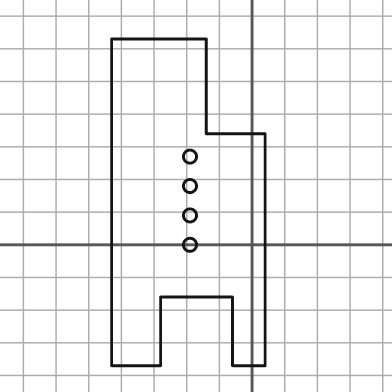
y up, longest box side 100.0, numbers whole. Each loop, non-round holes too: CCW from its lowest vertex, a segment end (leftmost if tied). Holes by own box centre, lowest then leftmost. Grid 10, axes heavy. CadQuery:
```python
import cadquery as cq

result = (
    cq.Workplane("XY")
    .moveTo(-43.0, -37.0)
    .lineTo(-28.0, -37.0)
    .lineTo(-28.0, -16.0)
    .lineTo(-6.0, -16.0)
    .lineTo(-6.0, -37.0)
    .lineTo(4.0, -37.0)
    .lineTo(4.0, 34.0)
    .lineTo(-14.0, 34.0)
    .lineTo(-14.0, 63.0)
    .lineTo(-43.0, 63.0)
    .close()
    .moveTo(-19.0, 0.0)
    .circle(2.0)
    .moveTo(-19.0, 9.0)
    .circle(2.0)
    .moveTo(-19.0, 18.0)
    .circle(2.0)
    .moveTo(-19.0, 27.0)
    .circle(2.0)
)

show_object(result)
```